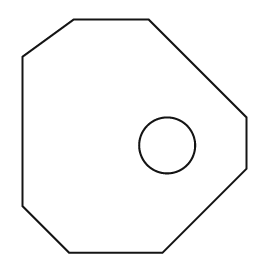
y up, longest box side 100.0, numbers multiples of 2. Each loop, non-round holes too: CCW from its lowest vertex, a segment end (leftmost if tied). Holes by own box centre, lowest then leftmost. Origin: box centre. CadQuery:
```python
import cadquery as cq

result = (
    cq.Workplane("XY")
    .moveTo(-28.0, -50.0)
    .lineTo(12.0, -50.0)
    .lineTo(48.0, -14.0)
    .lineTo(48.0, 8.0)
    .lineTo(6.0, 50.0)
    .lineTo(-26.0, 50.0)
    .lineTo(-48.0, 34.0)
    .lineTo(-48.0, -30.0)
    .close()
    .moveTo(14.0, -4.0)
    .circle(12.0)
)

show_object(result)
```